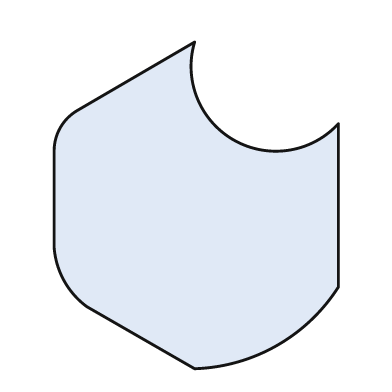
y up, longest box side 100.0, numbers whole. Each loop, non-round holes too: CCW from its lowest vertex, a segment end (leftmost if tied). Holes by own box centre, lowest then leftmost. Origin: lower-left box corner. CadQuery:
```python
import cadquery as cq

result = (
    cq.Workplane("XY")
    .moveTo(43.0, 0.0)
    .threePointArc((68.0, 7.0), (87.0, 25.0))
    .lineTo(87.0, 75.0)
    .threePointArc((55.0, 70.0), (43.0, 100.0))
    .lineTo(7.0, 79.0)
    .threePointArc((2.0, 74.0), (0.0, 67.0))
    .lineTo(0.0, 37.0)
    .threePointArc((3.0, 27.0), (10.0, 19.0))
    .close()
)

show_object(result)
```